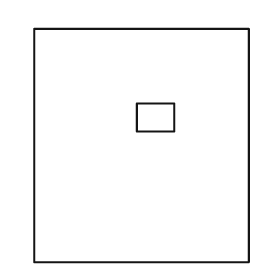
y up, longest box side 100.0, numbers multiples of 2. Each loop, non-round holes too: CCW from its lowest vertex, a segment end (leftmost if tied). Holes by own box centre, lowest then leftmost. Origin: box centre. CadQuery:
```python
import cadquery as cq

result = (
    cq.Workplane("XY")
    .moveTo(-46.0, -50.0)
    .lineTo(46.0, -50.0)
    .lineTo(46.0, 50.0)
    .lineTo(-46.0, 50.0)
    .close()
    .moveTo(-2.0, 6.0)
    .lineTo(14.0, 6.0)
    .lineTo(14.0, 18.0)
    .lineTo(-2.0, 18.0)
    .close()
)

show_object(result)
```